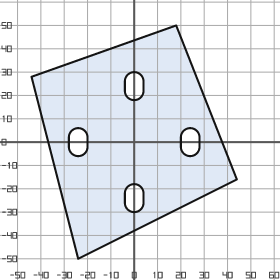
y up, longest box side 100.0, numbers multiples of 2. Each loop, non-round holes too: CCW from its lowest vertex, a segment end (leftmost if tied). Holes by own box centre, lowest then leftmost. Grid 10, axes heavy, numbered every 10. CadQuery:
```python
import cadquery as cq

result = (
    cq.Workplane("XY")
    .moveTo(-24.0, -50.0)
    .lineTo(44.0, -16.0)
    .lineTo(18.0, 50.0)
    .lineTo(-44.0, 28.0)
    .close()
    .moveTo(-4.0, -26.0)
    .threePointArc((0.0, -30.0), (4.0, -26.0))
    .lineTo(4.0, -22.0)
    .threePointArc((0.0, -18.0), (-4.0, -22.0))
    .close()
    .moveTo(-28.0, -2.0)
    .threePointArc((-24.0, -6.0), (-20.0, -2.0))
    .lineTo(-20.0, 2.0)
    .threePointArc((-24.0, 6.0), (-28.0, 2.0))
    .close()
    .moveTo(20.0, -2.0)
    .threePointArc((24.0, -6.0), (28.0, -2.0))
    .lineTo(28.0, 2.0)
    .threePointArc((24.0, 6.0), (20.0, 2.0))
    .close()
    .moveTo(-4.0, 22.0)
    .threePointArc((0.0, 18.0), (4.0, 22.0))
    .lineTo(4.0, 26.0)
    .threePointArc((0.0, 30.0), (-4.0, 26.0))
    .close()
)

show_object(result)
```